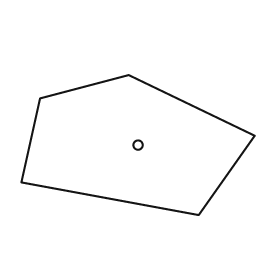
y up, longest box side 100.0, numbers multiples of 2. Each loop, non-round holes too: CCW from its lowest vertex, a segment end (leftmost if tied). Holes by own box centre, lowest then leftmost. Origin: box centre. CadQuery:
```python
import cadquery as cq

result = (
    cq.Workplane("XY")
    .moveTo(26.0, -30.0)
    .lineTo(50.0, 4.0)
    .lineTo(-4.0, 30.0)
    .lineTo(-42.0, 20.0)
    .lineTo(-50.0, -16.0)
    .close()
    .moveTo(0.0, 0.0)
    .circle(2.0)
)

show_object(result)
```